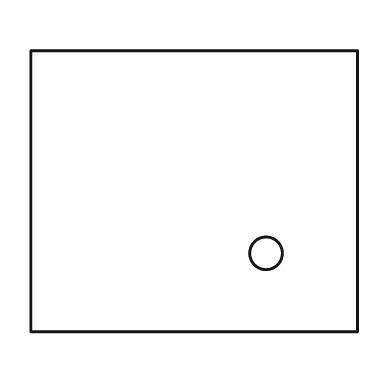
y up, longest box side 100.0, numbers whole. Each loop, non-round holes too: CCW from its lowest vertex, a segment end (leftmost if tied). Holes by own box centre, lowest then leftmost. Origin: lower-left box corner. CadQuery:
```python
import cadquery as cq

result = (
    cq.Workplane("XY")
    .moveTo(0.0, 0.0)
    .lineTo(100.0, 0.0)
    .lineTo(100.0, 86.0)
    .lineTo(0.0, 86.0)
    .close()
    .moveTo(72.0, 24.0)
    .circle(5.0)
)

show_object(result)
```